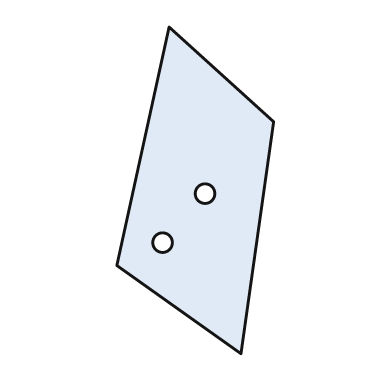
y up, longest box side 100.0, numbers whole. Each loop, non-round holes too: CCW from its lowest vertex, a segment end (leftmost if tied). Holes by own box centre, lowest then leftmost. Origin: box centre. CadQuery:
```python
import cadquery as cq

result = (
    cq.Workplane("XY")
    .moveTo(14.0, -50.0)
    .lineTo(24.0, 21.0)
    .lineTo(-8.0, 50.0)
    .lineTo(-24.0, -23.0)
    .close()
    .moveTo(-10.0, -16.0)
    .circle(3.0)
    .moveTo(3.0, -1.0)
    .circle(3.0)
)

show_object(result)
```